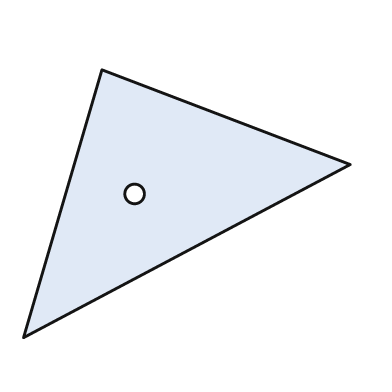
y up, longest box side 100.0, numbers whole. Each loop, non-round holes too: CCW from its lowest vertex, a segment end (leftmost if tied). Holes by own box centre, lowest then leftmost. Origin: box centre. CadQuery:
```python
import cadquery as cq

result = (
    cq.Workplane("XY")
    .moveTo(-50.0, -41.0)
    .lineTo(50.0, 12.0)
    .lineTo(-26.0, 41.0)
    .close()
    .moveTo(-16.0, 3.0)
    .circle(3.0)
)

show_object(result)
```